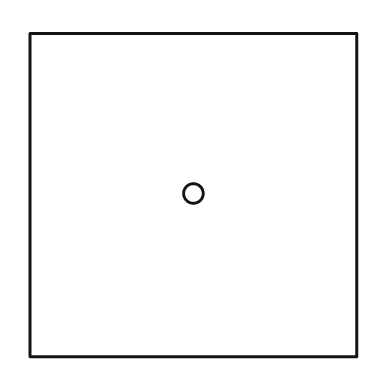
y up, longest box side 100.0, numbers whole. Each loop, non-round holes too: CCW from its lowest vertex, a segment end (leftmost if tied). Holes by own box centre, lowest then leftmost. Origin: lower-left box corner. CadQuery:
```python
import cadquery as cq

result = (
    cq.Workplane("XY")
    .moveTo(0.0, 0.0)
    .lineTo(100.0, 0.0)
    .lineTo(100.0, 99.0)
    .lineTo(0.0, 99.0)
    .close()
    .moveTo(50.0, 50.0)
    .circle(3.0)
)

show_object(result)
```